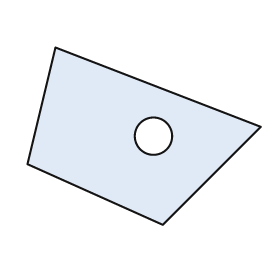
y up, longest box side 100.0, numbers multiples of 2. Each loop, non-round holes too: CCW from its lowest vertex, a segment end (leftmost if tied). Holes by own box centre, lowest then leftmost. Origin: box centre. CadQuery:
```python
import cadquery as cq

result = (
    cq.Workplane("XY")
    .moveTo(8.0, -38.0)
    .lineTo(50.0, 4.0)
    .lineTo(-38.0, 38.0)
    .lineTo(-50.0, -12.0)
    .close()
    .moveTo(4.0, 0.0)
    .circle(8.0)
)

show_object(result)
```